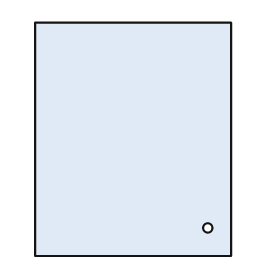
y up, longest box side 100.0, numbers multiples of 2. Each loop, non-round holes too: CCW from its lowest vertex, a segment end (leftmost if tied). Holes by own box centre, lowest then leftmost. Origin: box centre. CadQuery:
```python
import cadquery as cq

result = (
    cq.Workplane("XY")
    .moveTo(-42.0, -50.0)
    .lineTo(42.0, -50.0)
    .lineTo(42.0, 50.0)
    .lineTo(-42.0, 50.0)
    .close()
    .moveTo(32.0, -38.0)
    .circle(2.0)
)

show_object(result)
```